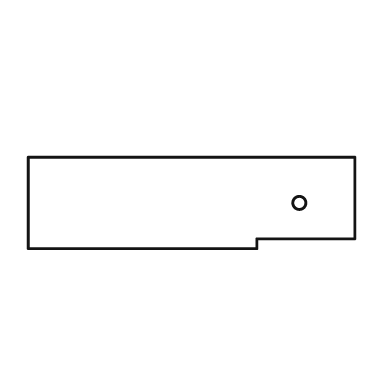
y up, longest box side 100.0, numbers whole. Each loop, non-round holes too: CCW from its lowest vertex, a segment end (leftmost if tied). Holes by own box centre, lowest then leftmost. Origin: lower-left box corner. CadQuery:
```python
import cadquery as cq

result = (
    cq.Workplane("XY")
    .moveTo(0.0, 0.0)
    .lineTo(70.0, 0.0)
    .lineTo(70.0, 3.0)
    .lineTo(100.0, 3.0)
    .lineTo(100.0, 28.0)
    .lineTo(0.0, 28.0)
    .close()
    .moveTo(83.0, 14.0)
    .circle(2.0)
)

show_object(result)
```